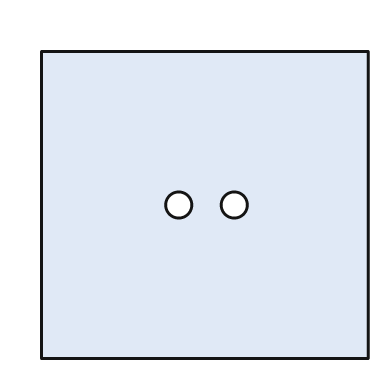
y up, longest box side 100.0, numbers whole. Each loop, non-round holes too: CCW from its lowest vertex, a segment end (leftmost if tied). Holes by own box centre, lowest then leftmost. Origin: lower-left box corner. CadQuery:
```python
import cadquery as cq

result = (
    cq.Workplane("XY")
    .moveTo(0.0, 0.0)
    .lineTo(100.0, 0.0)
    .lineTo(100.0, 94.0)
    .lineTo(0.0, 94.0)
    .close()
    .moveTo(42.0, 47.0)
    .circle(4.0)
    .moveTo(59.0, 47.0)
    .circle(4.0)
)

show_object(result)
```